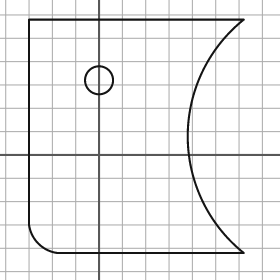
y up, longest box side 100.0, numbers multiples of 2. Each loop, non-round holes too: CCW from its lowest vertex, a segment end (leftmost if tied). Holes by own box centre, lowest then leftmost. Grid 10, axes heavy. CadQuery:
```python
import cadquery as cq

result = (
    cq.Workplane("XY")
    .moveTo(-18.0, -42.0)
    .lineTo(62.0, -42.0)
    .threePointArc((38.0, 8.0), (62.0, 58.0))
    .lineTo(-30.0, 58.0)
    .lineTo(-30.0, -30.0)
    .threePointArc((-26.0, -38.0), (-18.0, -42.0))
    .close()
    .moveTo(0.0, 32.0)
    .circle(6.0)
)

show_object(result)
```